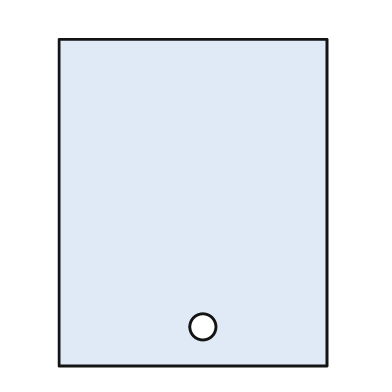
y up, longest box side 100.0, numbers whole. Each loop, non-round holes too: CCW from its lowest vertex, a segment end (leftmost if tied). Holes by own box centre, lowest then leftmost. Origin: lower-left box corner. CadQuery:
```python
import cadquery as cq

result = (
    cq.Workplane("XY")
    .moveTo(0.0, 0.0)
    .lineTo(82.0, 0.0)
    .lineTo(82.0, 100.0)
    .lineTo(0.0, 100.0)
    .close()
    .moveTo(44.0, 12.0)
    .circle(4.0)
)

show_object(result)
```